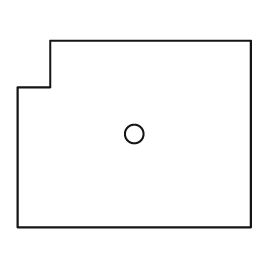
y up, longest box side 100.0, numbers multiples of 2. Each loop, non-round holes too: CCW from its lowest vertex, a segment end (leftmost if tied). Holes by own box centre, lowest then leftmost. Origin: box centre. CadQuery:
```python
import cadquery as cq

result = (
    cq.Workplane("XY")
    .moveTo(-50.0, -40.0)
    .lineTo(50.0, -40.0)
    .lineTo(50.0, 40.0)
    .lineTo(-36.0, 40.0)
    .lineTo(-36.0, 20.0)
    .lineTo(-50.0, 20.0)
    .close()
    .moveTo(0.0, 0.0)
    .circle(4.0)
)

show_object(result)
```